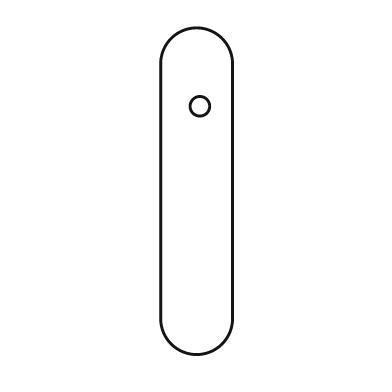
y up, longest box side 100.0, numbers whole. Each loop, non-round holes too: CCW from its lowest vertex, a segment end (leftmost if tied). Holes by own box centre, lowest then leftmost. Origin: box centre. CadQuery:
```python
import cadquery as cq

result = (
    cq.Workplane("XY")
    .moveTo(-11.0, -39.0)
    .threePointArc((0.0, -50.0), (11.0, -39.0))
    .lineTo(11.0, 39.0)
    .threePointArc((0.0, 50.0), (-11.0, 39.0))
    .close()
    .moveTo(1.0, 26.0)
    .circle(3.0)
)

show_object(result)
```